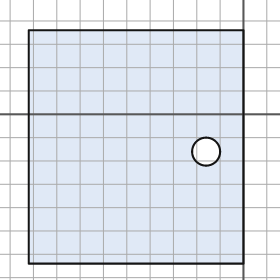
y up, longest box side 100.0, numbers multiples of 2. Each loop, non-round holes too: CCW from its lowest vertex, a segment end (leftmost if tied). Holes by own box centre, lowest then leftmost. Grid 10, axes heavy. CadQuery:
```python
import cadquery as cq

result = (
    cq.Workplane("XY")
    .moveTo(-92.0, -64.0)
    .lineTo(0.0, -64.0)
    .lineTo(0.0, 36.0)
    .lineTo(-92.0, 36.0)
    .close()
    .moveTo(-16.0, -16.0)
    .circle(6.0)
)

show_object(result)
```